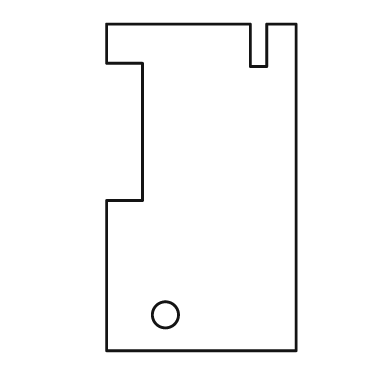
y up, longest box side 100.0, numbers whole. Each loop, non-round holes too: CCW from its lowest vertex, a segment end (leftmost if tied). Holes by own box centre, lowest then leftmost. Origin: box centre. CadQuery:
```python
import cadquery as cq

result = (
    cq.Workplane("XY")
    .moveTo(-29.0, -50.0)
    .lineTo(29.0, -50.0)
    .lineTo(29.0, 50.0)
    .lineTo(20.0, 50.0)
    .lineTo(20.0, 37.0)
    .lineTo(15.0, 37.0)
    .lineTo(15.0, 50.0)
    .lineTo(-29.0, 50.0)
    .lineTo(-29.0, 38.0)
    .lineTo(-18.0, 38.0)
    .lineTo(-18.0, -4.0)
    .lineTo(-29.0, -4.0)
    .close()
    .moveTo(-11.0, -39.0)
    .circle(4.0)
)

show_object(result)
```